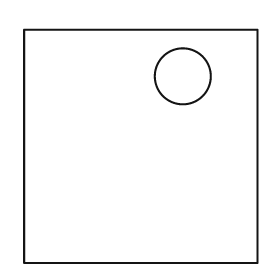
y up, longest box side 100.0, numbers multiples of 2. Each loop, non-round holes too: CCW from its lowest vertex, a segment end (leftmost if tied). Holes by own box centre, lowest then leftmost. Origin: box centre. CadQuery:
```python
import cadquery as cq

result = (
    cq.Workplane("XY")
    .moveTo(-50.0, -50.0)
    .lineTo(50.0, -50.0)
    .lineTo(50.0, 50.0)
    .lineTo(-50.0, 50.0)
    .close()
    .moveTo(18.0, 30.0)
    .circle(12.0)
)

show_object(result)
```